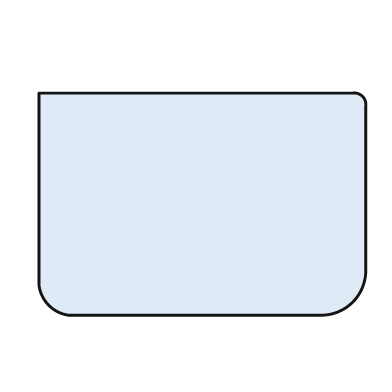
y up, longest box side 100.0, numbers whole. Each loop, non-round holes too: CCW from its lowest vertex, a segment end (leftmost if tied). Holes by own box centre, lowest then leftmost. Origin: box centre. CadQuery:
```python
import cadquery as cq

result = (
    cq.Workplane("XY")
    .moveTo(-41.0, -34.0)
    .lineTo(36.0, -34.0)
    .threePointArc((46.0, -30.0), (50.0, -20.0))
    .lineTo(50.0, 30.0)
    .threePointArc((49.0, 33.0), (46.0, 34.0))
    .lineTo(-50.0, 34.0)
    .lineTo(-50.0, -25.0)
    .threePointArc((-47.0, -31.0), (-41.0, -34.0))
    .close()
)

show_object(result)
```